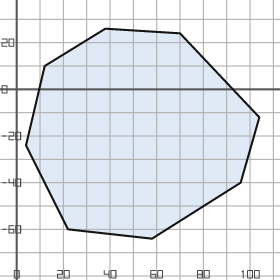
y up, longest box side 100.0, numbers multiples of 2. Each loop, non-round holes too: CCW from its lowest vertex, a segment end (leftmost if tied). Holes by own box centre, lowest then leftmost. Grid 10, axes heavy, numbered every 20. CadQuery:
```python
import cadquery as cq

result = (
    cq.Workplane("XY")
    .moveTo(58.0, -64.0)
    .lineTo(96.0, -40.0)
    .lineTo(104.0, -12.0)
    .lineTo(70.0, 24.0)
    .lineTo(38.0, 26.0)
    .lineTo(12.0, 10.0)
    .lineTo(4.0, -24.0)
    .lineTo(22.0, -60.0)
    .close()
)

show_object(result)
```